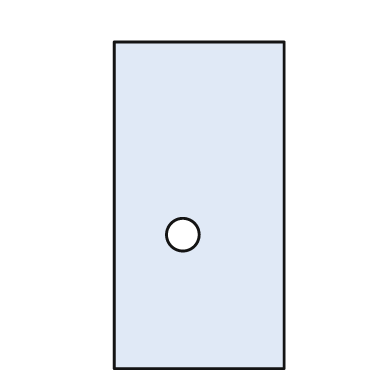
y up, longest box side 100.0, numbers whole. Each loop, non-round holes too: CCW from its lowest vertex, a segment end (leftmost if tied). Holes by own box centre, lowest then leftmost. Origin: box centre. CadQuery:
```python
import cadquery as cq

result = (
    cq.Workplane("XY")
    .moveTo(-26.0, -50.0)
    .lineTo(26.0, -50.0)
    .lineTo(26.0, 50.0)
    .lineTo(-26.0, 50.0)
    .close()
    .moveTo(-5.0, -9.0)
    .circle(5.0)
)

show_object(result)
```